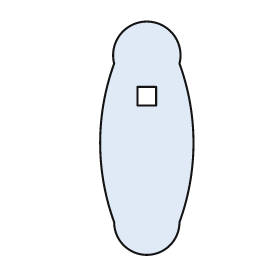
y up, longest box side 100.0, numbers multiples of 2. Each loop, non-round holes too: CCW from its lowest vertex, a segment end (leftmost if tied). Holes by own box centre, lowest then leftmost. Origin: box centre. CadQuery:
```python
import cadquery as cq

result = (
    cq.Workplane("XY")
    .moveTo(-14.0, -36.0)
    .threePointArc((0.0, -50.0), (14.0, -36.0))
    .threePointArc((20.0, -2.0), (14.0, 32.0))
    .threePointArc((0.0, 50.0), (-14.0, 32.0))
    .threePointArc((-20.0, -2.0), (-14.0, -36.0))
    .close()
    .moveTo(-4.0, 14.0)
    .lineTo(4.0, 14.0)
    .lineTo(4.0, 22.0)
    .lineTo(-4.0, 22.0)
    .close()
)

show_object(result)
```